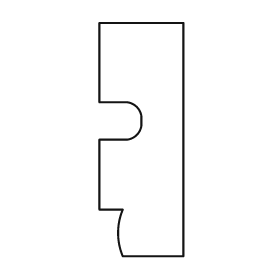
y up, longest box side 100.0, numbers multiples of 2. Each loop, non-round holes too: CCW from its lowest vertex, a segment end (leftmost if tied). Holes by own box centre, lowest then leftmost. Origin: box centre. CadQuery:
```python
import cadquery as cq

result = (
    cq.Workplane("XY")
    .moveTo(-8.0, -50.0)
    .lineTo(18.0, -50.0)
    .lineTo(18.0, 50.0)
    .lineTo(-18.0, 50.0)
    .lineTo(-18.0, 16.0)
    .lineTo(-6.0, 16.0)
    .threePointArc((-2.0, 14.0), (0.0, 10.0))
    .lineTo(0.0, 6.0)
    .threePointArc((-2.0, 2.0), (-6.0, 0.0))
    .lineTo(-18.0, 0.0)
    .lineTo(-18.0, -30.0)
    .lineTo(-8.0, -30.0)
    .threePointArc((-10.0, -40.0), (-8.0, -50.0))
    .close()
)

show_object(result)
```